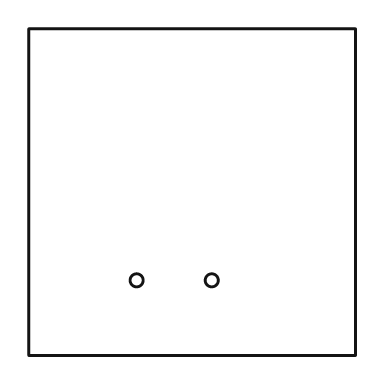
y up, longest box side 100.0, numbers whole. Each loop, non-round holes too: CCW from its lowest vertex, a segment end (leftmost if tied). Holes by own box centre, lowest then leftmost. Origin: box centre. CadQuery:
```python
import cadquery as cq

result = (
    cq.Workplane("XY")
    .moveTo(-50.0, -50.0)
    .lineTo(50.0, -50.0)
    .lineTo(50.0, 50.0)
    .lineTo(-50.0, 50.0)
    .close()
    .moveTo(-17.0, -27.0)
    .circle(2.0)
    .moveTo(6.0, -27.0)
    .circle(2.0)
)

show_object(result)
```